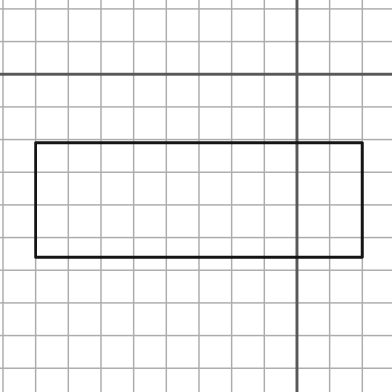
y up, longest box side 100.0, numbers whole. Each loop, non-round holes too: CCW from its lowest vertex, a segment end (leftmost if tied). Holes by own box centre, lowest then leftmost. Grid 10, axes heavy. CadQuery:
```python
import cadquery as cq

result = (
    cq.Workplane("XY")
    .moveTo(-80.0, -56.0)
    .lineTo(20.0, -56.0)
    .lineTo(20.0, -21.0)
    .lineTo(-80.0, -21.0)
    .close()
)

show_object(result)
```